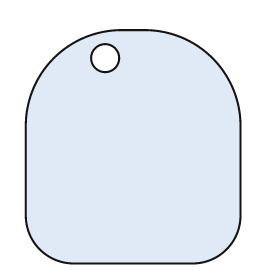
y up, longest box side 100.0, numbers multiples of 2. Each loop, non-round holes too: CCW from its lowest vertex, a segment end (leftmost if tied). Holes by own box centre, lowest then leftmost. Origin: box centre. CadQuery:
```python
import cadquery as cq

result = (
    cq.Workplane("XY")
    .moveTo(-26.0, -50.0)
    .lineTo(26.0, -50.0)
    .threePointArc((40.0, -44.0), (46.0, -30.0))
    .lineTo(46.0, 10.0)
    .threePointArc((34.0, 38.0), (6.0, 50.0))
    .lineTo(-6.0, 50.0)
    .threePointArc((-34.0, 38.0), (-46.0, 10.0))
    .lineTo(-46.0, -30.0)
    .threePointArc((-40.0, -44.0), (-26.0, -50.0))
    .close()
    .moveTo(-12.0, 38.0)
    .circle(6.0)
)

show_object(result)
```